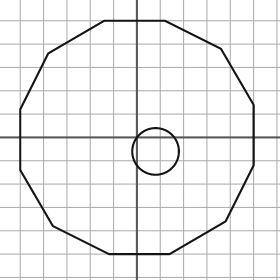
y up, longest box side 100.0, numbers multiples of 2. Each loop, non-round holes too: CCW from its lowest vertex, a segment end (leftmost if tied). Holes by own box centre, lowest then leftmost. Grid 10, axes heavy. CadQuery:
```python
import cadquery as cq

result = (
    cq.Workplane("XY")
    .moveTo(-12.0, -50.0)
    .lineTo(14.0, -50.0)
    .lineTo(38.0, -36.0)
    .lineTo(50.0, -12.0)
    .lineTo(50.0, 14.0)
    .lineTo(36.0, 38.0)
    .lineTo(12.0, 50.0)
    .lineTo(-14.0, 50.0)
    .lineTo(-38.0, 36.0)
    .lineTo(-50.0, 12.0)
    .lineTo(-50.0, -14.0)
    .lineTo(-36.0, -38.0)
    .close()
    .moveTo(8.0, -6.0)
    .circle(10.0)
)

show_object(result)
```